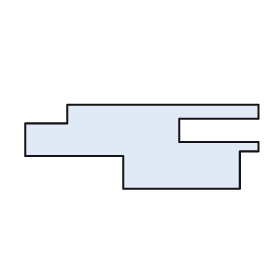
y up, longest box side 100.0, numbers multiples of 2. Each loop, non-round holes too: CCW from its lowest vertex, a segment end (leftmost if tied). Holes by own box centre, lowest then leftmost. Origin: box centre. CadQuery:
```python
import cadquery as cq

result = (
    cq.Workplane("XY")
    .moveTo(-8.0, -18.0)
    .lineTo(42.0, -18.0)
    .lineTo(42.0, -2.0)
    .lineTo(50.0, -2.0)
    .lineTo(50.0, 2.0)
    .lineTo(16.0, 2.0)
    .lineTo(16.0, 12.0)
    .lineTo(50.0, 12.0)
    .lineTo(50.0, 18.0)
    .lineTo(-32.0, 18.0)
    .lineTo(-32.0, 10.0)
    .lineTo(-50.0, 10.0)
    .lineTo(-50.0, -4.0)
    .lineTo(-8.0, -4.0)
    .close()
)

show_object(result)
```